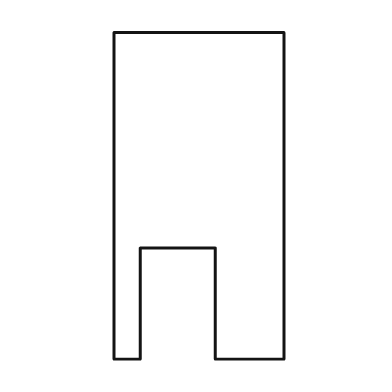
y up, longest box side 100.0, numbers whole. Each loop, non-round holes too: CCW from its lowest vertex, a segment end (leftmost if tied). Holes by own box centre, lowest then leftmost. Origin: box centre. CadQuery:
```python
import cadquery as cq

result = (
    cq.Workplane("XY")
    .moveTo(-26.0, -50.0)
    .lineTo(-18.0, -50.0)
    .lineTo(-18.0, -16.0)
    .lineTo(5.0, -16.0)
    .lineTo(5.0, -50.0)
    .lineTo(26.0, -50.0)
    .lineTo(26.0, 50.0)
    .lineTo(-26.0, 50.0)
    .close()
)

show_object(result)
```